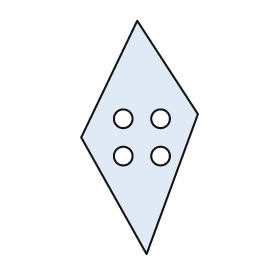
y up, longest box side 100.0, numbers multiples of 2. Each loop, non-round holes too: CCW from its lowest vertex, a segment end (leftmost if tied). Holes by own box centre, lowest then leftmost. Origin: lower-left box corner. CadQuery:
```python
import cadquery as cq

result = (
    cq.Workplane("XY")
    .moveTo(28.0, 0.0)
    .lineTo(50.0, 60.0)
    .lineTo(24.0, 100.0)
    .lineTo(0.0, 50.0)
    .close()
    .moveTo(18.0, 42.0)
    .circle(4.0)
    .moveTo(34.0, 42.0)
    .circle(4.0)
    .moveTo(18.0, 58.0)
    .circle(4.0)
    .moveTo(34.0, 58.0)
    .circle(4.0)
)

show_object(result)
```